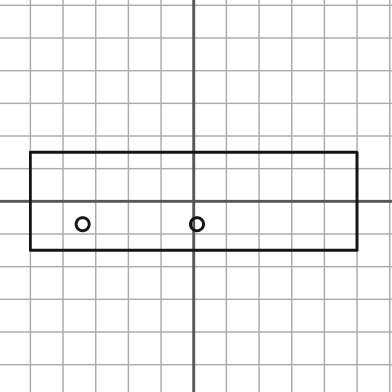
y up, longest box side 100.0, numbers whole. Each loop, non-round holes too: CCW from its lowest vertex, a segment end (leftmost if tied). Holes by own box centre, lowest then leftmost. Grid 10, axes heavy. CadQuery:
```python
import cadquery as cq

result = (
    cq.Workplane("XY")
    .moveTo(-50.0, -15.0)
    .lineTo(50.0, -15.0)
    .lineTo(50.0, 15.0)
    .lineTo(-50.0, 15.0)
    .close()
    .moveTo(-34.0, -7.0)
    .circle(2.0)
    .moveTo(1.0, -7.0)
    .circle(2.0)
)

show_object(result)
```